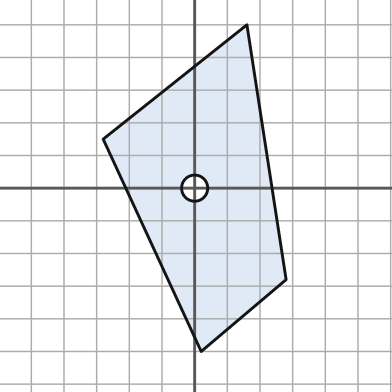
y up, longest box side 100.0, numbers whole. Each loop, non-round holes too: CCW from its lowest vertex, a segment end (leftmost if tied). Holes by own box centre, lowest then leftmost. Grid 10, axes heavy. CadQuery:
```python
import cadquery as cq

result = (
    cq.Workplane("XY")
    .moveTo(2.0, -50.0)
    .lineTo(28.0, -28.0)
    .lineTo(16.0, 50.0)
    .lineTo(-28.0, 15.0)
    .close()
    .moveTo(0.0, 0.0)
    .circle(4.0)
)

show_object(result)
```